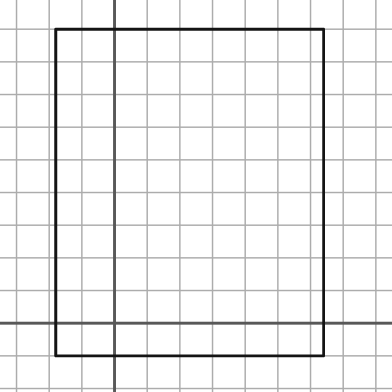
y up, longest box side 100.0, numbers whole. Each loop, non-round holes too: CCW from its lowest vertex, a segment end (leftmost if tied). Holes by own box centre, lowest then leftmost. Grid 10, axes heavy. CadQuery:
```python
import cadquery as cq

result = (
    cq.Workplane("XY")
    .moveTo(-18.0, -10.0)
    .lineTo(64.0, -10.0)
    .lineTo(64.0, 90.0)
    .lineTo(-18.0, 90.0)
    .close()
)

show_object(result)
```